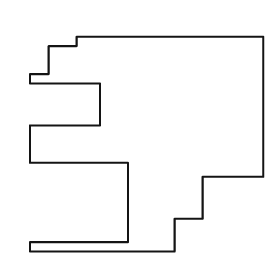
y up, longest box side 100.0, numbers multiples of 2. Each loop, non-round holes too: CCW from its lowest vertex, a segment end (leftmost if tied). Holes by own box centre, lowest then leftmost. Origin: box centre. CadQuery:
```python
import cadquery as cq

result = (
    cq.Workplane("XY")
    .moveTo(-50.0, -46.0)
    .lineTo(12.0, -46.0)
    .lineTo(12.0, -32.0)
    .lineTo(24.0, -32.0)
    .lineTo(24.0, -14.0)
    .lineTo(50.0, -14.0)
    .lineTo(50.0, 46.0)
    .lineTo(-30.0, 46.0)
    .lineTo(-30.0, 42.0)
    .lineTo(-42.0, 42.0)
    .lineTo(-42.0, 30.0)
    .lineTo(-50.0, 30.0)
    .lineTo(-50.0, 26.0)
    .lineTo(-20.0, 26.0)
    .lineTo(-20.0, 8.0)
    .lineTo(-50.0, 8.0)
    .lineTo(-50.0, -8.0)
    .lineTo(-8.0, -8.0)
    .lineTo(-8.0, -42.0)
    .lineTo(-50.0, -42.0)
    .close()
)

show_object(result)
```